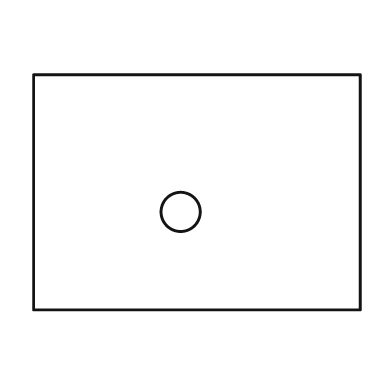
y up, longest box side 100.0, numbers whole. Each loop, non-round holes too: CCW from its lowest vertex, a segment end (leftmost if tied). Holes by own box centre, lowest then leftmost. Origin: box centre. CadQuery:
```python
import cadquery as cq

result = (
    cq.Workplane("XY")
    .moveTo(-50.0, -36.0)
    .lineTo(50.0, -36.0)
    .lineTo(50.0, 36.0)
    .lineTo(-50.0, 36.0)
    .close()
    .moveTo(-5.0, -6.0)
    .circle(6.0)
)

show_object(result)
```